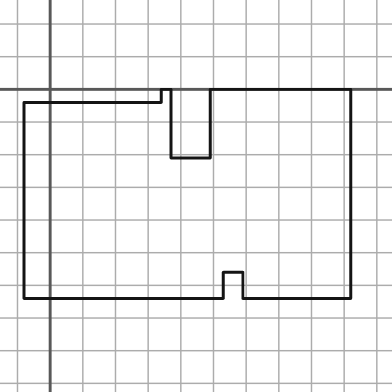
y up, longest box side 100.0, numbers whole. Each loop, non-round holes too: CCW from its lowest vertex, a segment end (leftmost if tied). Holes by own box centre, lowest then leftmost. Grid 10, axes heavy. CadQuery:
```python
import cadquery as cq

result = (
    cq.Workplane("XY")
    .moveTo(-8.0, -64.0)
    .lineTo(53.0, -64.0)
    .lineTo(53.0, -56.0)
    .lineTo(59.0, -56.0)
    .lineTo(59.0, -64.0)
    .lineTo(92.0, -64.0)
    .lineTo(92.0, 0.0)
    .lineTo(49.0, 0.0)
    .lineTo(49.0, -21.0)
    .lineTo(37.0, -21.0)
    .lineTo(37.0, 0.0)
    .lineTo(34.0, 0.0)
    .lineTo(34.0, -4.0)
    .lineTo(-8.0, -4.0)
    .close()
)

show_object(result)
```